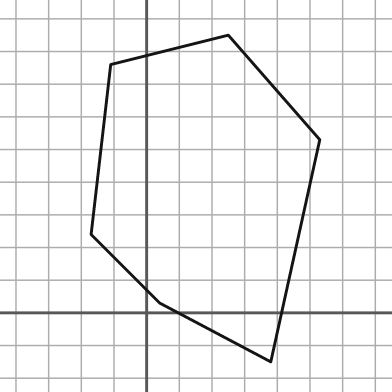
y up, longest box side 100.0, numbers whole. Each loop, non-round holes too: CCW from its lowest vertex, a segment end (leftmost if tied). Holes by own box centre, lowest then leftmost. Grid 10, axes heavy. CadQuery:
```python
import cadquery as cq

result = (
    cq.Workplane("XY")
    .moveTo(38.0, -15.0)
    .lineTo(53.0, 53.0)
    .lineTo(25.0, 85.0)
    .lineTo(-11.0, 76.0)
    .lineTo(-17.0, 24.0)
    .lineTo(4.0, 3.0)
    .close()
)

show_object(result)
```